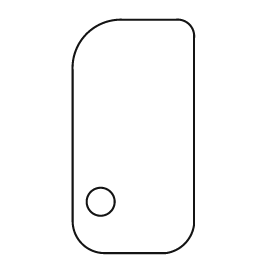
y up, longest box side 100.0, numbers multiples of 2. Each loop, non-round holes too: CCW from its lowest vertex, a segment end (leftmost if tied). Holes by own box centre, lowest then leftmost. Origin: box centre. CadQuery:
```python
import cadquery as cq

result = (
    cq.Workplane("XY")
    .moveTo(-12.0, -50.0)
    .lineTo(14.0, -50.0)
    .threePointArc((22.0, -46.0), (26.0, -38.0))
    .lineTo(26.0, 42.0)
    .threePointArc((24.0, 48.0), (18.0, 50.0))
    .lineTo(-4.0, 50.0)
    .threePointArc((-20.0, 44.0), (-26.0, 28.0))
    .lineTo(-26.0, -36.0)
    .threePointArc((-22.0, -46.0), (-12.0, -50.0))
    .close()
    .moveTo(-14.0, -28.0)
    .circle(6.0)
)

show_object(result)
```